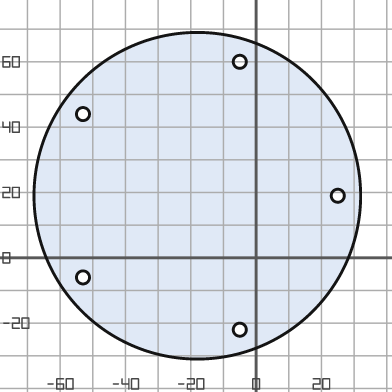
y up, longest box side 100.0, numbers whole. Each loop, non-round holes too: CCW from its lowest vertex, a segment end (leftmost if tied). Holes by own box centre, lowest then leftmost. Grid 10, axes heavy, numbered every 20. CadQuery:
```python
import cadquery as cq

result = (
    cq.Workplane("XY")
    .moveTo(-18.0, 19.0)
    .circle(50.0)
    .moveTo(-5.0, -22.0)
    .circle(2.0)
    .moveTo(-53.0, -6.0)
    .circle(2.0)
    .moveTo(25.0, 19.0)
    .circle(2.0)
    .moveTo(-53.0, 44.0)
    .circle(2.0)
    .moveTo(-5.0, 60.0)
    .circle(2.0)
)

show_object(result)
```